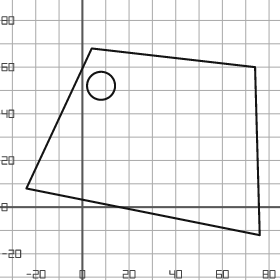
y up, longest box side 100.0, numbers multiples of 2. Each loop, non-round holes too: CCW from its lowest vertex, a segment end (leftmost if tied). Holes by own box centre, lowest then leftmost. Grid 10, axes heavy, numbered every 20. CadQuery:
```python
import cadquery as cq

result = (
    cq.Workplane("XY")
    .moveTo(76.0, -12.0)
    .lineTo(74.0, 60.0)
    .lineTo(4.0, 68.0)
    .lineTo(-24.0, 8.0)
    .close()
    .moveTo(8.0, 52.0)
    .circle(6.0)
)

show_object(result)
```